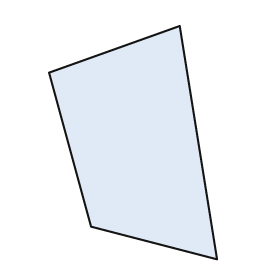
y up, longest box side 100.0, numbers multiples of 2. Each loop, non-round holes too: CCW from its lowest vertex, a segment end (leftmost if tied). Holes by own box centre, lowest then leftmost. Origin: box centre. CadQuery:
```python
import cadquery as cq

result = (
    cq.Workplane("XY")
    .moveTo(36.0, -50.0)
    .lineTo(20.0, 50.0)
    .lineTo(-36.0, 30.0)
    .lineTo(-18.0, -36.0)
    .close()
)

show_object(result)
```